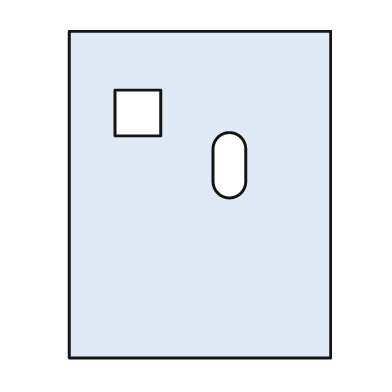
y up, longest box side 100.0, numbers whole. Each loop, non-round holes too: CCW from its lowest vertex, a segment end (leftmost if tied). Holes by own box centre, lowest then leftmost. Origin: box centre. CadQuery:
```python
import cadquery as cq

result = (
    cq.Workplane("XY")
    .moveTo(-40.0, -50.0)
    .lineTo(40.0, -50.0)
    .lineTo(40.0, 50.0)
    .lineTo(-40.0, 50.0)
    .close()
    .moveTo(4.0, 4.0)
    .threePointArc((9.0, -1.0), (14.0, 4.0))
    .lineTo(14.0, 14.0)
    .threePointArc((9.0, 19.0), (4.0, 14.0))
    .close()
    .moveTo(-26.0, 18.0)
    .lineTo(-12.0, 18.0)
    .lineTo(-12.0, 32.0)
    .lineTo(-26.0, 32.0)
    .close()
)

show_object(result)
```